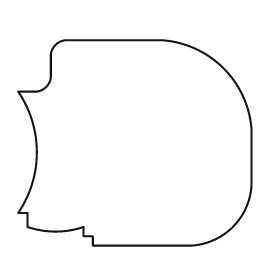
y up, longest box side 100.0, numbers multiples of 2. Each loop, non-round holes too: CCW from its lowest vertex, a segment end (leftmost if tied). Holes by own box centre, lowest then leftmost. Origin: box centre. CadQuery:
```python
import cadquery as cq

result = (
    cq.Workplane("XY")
    .moveTo(-18.0, -44.0)
    .lineTo(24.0, -44.0)
    .threePointArc((42.0, -36.0), (50.0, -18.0))
    .lineTo(50.0, 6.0)
    .threePointArc((38.0, 32.0), (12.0, 44.0))
    .lineTo(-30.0, 44.0)
    .threePointArc((-34.0, 42.0), (-36.0, 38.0))
    .lineTo(-36.0, 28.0)
    .threePointArc((-38.0, 24.0), (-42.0, 22.0))
    .lineTo(-50.0, 22.0)
    .threePointArc((-42.0, -4.0), (-50.0, -30.0))
    .lineTo(-46.0, -30.0)
    .lineTo(-46.0, -36.0)
    .threePointArc((-34.0, -38.0), (-22.0, -36.0))
    .lineTo(-22.0, -40.0)
    .lineTo(-18.0, -40.0)
    .close()
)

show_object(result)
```